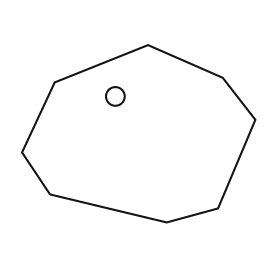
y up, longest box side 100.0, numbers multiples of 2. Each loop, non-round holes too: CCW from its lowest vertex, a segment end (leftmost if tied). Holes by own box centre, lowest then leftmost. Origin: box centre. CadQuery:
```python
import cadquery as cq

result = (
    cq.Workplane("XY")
    .moveTo(12.0, -38.0)
    .lineTo(34.0, -32.0)
    .lineTo(50.0, 6.0)
    .lineTo(36.0, 24.0)
    .lineTo(4.0, 38.0)
    .lineTo(-36.0, 22.0)
    .lineTo(-50.0, -8.0)
    .lineTo(-38.0, -26.0)
    .close()
    .moveTo(-10.0, 16.0)
    .circle(4.0)
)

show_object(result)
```